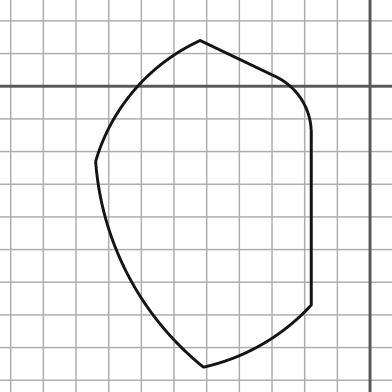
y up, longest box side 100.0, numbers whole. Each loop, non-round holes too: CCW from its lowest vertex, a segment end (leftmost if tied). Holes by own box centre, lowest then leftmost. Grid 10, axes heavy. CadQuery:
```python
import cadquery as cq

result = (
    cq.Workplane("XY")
    .moveTo(-51.0, -86.0)
    .threePointArc((-33.0, -79.0), (-18.0, -67.0))
    .lineTo(-18.0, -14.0)
    .threePointArc((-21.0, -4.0), (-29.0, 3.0))
    .lineTo(-52.0, 14.0)
    .threePointArc((-72.0, -1.0), (-84.0, -23.0))
    .threePointArc((-74.0, -58.0), (-51.0, -86.0))
    .close()
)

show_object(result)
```